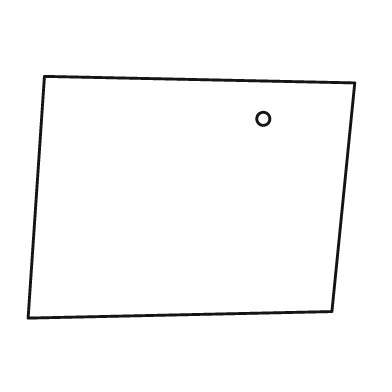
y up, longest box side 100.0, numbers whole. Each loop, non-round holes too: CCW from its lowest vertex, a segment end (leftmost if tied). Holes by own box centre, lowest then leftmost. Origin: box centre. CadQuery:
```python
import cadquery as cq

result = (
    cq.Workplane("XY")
    .moveTo(-50.0, -37.0)
    .lineTo(43.0, -35.0)
    .lineTo(50.0, 35.0)
    .lineTo(-45.0, 37.0)
    .close()
    .moveTo(22.0, 24.0)
    .circle(2.0)
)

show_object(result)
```